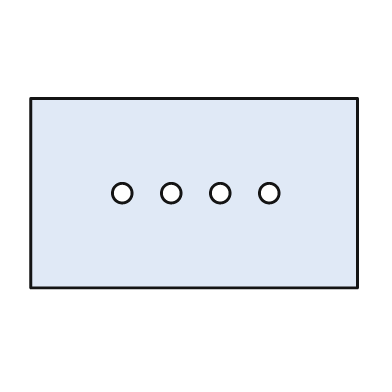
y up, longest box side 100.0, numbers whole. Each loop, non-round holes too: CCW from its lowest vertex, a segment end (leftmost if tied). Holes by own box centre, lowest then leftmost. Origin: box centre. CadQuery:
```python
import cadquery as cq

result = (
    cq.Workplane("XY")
    .moveTo(-50.0, -29.0)
    .lineTo(50.0, -29.0)
    .lineTo(50.0, 29.0)
    .lineTo(-50.0, 29.0)
    .close()
    .moveTo(-22.0, 0.0)
    .circle(3.0)
    .moveTo(-7.0, 0.0)
    .circle(3.0)
    .moveTo(8.0, 0.0)
    .circle(3.0)
    .moveTo(23.0, 0.0)
    .circle(3.0)
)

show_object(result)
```